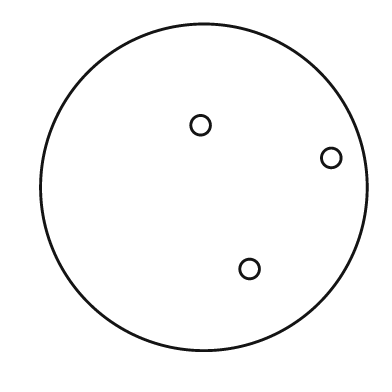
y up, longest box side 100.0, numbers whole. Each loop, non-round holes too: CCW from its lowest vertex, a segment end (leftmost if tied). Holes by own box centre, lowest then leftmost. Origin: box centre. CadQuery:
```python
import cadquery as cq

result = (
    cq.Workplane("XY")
    .moveTo(0.0, 0.0)
    .circle(50.0)
    .moveTo(14.0, -25.0)
    .circle(3.0)
    .moveTo(39.0, 9.0)
    .circle(3.0)
    .moveTo(-1.0, 19.0)
    .circle(3.0)
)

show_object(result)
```